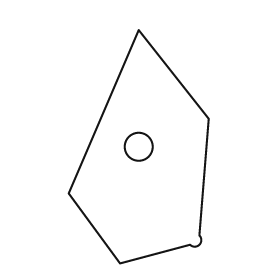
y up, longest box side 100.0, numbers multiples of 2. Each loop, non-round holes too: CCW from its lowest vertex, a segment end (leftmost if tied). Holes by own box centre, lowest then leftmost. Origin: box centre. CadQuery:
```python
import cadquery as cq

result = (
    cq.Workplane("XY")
    .moveTo(-8.0, -50.0)
    .lineTo(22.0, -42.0)
    .threePointArc((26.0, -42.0), (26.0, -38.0))
    .lineTo(30.0, 12.0)
    .lineTo(0.0, 50.0)
    .lineTo(-30.0, -20.0)
    .close()
    .moveTo(0.0, 0.0)
    .circle(6.0)
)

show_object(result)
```